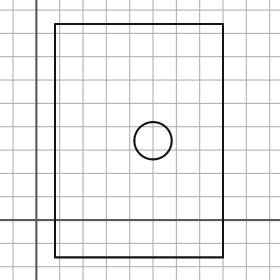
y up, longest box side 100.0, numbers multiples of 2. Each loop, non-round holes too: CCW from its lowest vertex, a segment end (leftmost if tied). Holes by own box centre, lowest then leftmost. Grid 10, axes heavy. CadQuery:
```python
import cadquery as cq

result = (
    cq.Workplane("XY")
    .moveTo(8.0, -16.0)
    .lineTo(80.0, -16.0)
    .lineTo(80.0, 84.0)
    .lineTo(8.0, 84.0)
    .close()
    .moveTo(50.0, 34.0)
    .circle(8.0)
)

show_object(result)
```